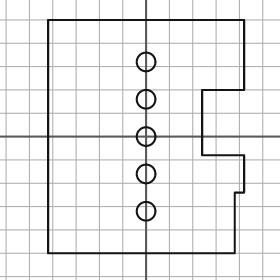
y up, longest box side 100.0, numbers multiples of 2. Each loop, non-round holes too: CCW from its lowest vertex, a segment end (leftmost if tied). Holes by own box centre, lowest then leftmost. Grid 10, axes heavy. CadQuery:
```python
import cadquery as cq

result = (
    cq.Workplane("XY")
    .moveTo(-42.0, -50.0)
    .lineTo(38.0, -50.0)
    .lineTo(38.0, -24.0)
    .lineTo(42.0, -24.0)
    .lineTo(42.0, -8.0)
    .lineTo(24.0, -8.0)
    .lineTo(24.0, 20.0)
    .lineTo(42.0, 20.0)
    .lineTo(42.0, 50.0)
    .lineTo(-42.0, 50.0)
    .close()
    .moveTo(0.0, -32.0)
    .circle(4.0)
    .moveTo(0.0, -16.0)
    .circle(4.0)
    .moveTo(0.0, 0.0)
    .circle(4.0)
    .moveTo(0.0, 16.0)
    .circle(4.0)
    .moveTo(0.0, 32.0)
    .circle(4.0)
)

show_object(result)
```